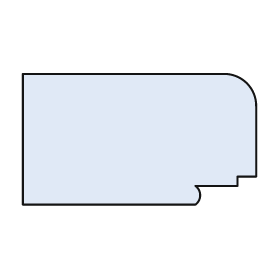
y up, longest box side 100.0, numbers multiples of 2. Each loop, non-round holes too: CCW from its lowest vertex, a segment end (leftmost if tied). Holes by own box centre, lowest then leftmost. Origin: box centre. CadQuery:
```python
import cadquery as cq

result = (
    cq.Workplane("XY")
    .moveTo(-50.0, -28.0)
    .lineTo(24.0, -28.0)
    .threePointArc((26.0, -24.0), (24.0, -20.0))
    .lineTo(42.0, -20.0)
    .lineTo(42.0, -16.0)
    .lineTo(50.0, -16.0)
    .lineTo(50.0, 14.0)
    .threePointArc((46.0, 24.0), (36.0, 28.0))
    .lineTo(-50.0, 28.0)
    .close()
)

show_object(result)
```